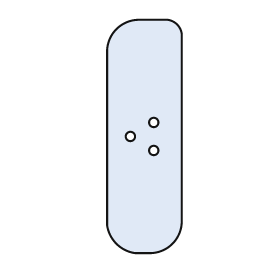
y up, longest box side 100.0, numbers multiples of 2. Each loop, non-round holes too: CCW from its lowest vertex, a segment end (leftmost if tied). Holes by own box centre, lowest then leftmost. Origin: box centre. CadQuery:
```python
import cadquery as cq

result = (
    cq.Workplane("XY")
    .moveTo(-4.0, -50.0)
    .lineTo(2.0, -50.0)
    .threePointArc((12.0, -46.0), (16.0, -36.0))
    .lineTo(16.0, 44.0)
    .threePointArc((14.0, 48.0), (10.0, 50.0))
    .lineTo(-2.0, 50.0)
    .threePointArc((-12.0, 46.0), (-16.0, 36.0))
    .lineTo(-16.0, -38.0)
    .threePointArc((-12.0, -46.0), (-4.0, -50.0))
    .close()
    .moveTo(4.0, -6.0)
    .circle(2.0)
    .moveTo(-6.0, 0.0)
    .circle(2.0)
    .moveTo(4.0, 6.0)
    .circle(2.0)
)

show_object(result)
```